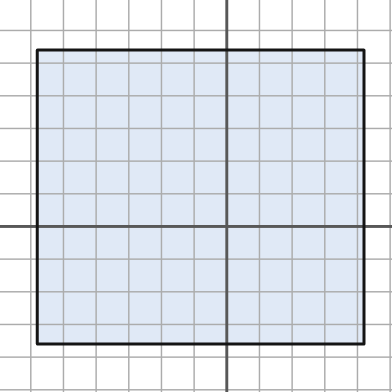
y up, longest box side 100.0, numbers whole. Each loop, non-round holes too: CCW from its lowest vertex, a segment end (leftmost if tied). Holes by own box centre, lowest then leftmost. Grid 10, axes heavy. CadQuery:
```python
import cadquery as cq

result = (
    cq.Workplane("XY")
    .moveTo(-58.0, -36.0)
    .lineTo(42.0, -36.0)
    .lineTo(42.0, 54.0)
    .lineTo(-58.0, 54.0)
    .close()
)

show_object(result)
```